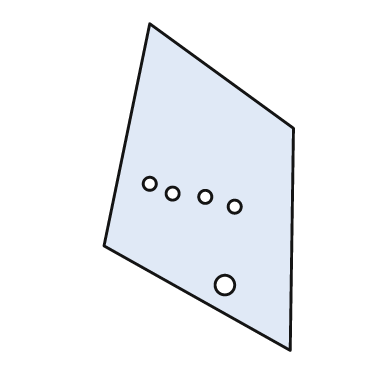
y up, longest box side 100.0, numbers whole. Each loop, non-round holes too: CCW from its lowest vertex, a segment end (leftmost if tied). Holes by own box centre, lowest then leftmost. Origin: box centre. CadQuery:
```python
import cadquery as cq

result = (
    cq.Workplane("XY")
    .moveTo(28.0, -50.0)
    .lineTo(29.0, 18.0)
    .lineTo(-15.0, 50.0)
    .lineTo(-29.0, -18.0)
    .close()
    .moveTo(8.0, -30.0)
    .circle(3.0)
    .moveTo(11.0, -6.0)
    .circle(2.0)
    .moveTo(2.0, -3.0)
    .circle(2.0)
    .moveTo(-8.0, -2.0)
    .circle(2.0)
    .moveTo(-15.0, 1.0)
    .circle(2.0)
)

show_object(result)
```